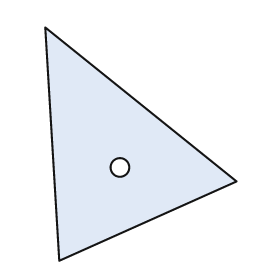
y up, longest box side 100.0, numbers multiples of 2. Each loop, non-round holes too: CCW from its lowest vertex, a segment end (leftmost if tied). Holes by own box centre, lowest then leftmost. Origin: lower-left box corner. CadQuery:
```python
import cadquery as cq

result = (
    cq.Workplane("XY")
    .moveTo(6.0, 0.0)
    .lineTo(82.0, 34.0)
    .lineTo(0.0, 100.0)
    .close()
    .moveTo(32.0, 40.0)
    .circle(4.0)
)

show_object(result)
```